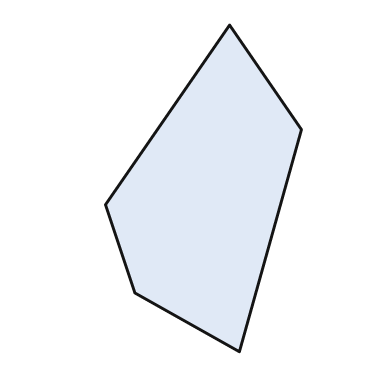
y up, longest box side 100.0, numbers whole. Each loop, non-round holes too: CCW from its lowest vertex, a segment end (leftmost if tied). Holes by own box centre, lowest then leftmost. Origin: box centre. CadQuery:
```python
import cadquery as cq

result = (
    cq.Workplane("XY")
    .moveTo(11.0, -50.0)
    .lineTo(30.0, 18.0)
    .lineTo(8.0, 50.0)
    .lineTo(-30.0, -5.0)
    .lineTo(-21.0, -32.0)
    .close()
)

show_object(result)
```